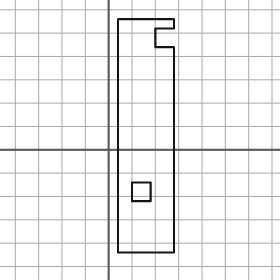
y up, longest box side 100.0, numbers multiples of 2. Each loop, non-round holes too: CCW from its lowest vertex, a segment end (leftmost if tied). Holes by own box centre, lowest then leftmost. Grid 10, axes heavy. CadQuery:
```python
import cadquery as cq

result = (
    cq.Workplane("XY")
    .moveTo(4.0, -44.0)
    .lineTo(28.0, -44.0)
    .lineTo(28.0, 44.0)
    .lineTo(20.0, 44.0)
    .lineTo(20.0, 52.0)
    .lineTo(28.0, 52.0)
    .lineTo(28.0, 56.0)
    .lineTo(4.0, 56.0)
    .close()
    .moveTo(10.0, -22.0)
    .lineTo(18.0, -22.0)
    .lineTo(18.0, -14.0)
    .lineTo(10.0, -14.0)
    .close()
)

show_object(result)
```